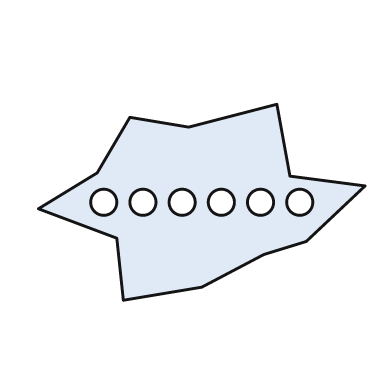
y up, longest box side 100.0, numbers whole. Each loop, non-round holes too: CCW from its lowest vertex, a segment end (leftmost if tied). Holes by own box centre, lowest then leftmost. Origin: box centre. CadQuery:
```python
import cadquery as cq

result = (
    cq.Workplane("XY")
    .moveTo(-24.0, -30.0)
    .lineTo(0.0, -26.0)
    .lineTo(19.0, -16.0)
    .lineTo(32.0, -12.0)
    .lineTo(50.0, 5.0)
    .lineTo(27.0, 8.0)
    .lineTo(23.0, 30.0)
    .lineTo(-4.0, 23.0)
    .lineTo(-22.0, 26.0)
    .lineTo(-32.0, 9.0)
    .lineTo(-50.0, -2.0)
    .lineTo(-26.0, -11.0)
    .close()
    .moveTo(-30.0, 0.0)
    .circle(4.0)
    .moveTo(-18.0, 0.0)
    .circle(4.0)
    .moveTo(-6.0, 0.0)
    .circle(4.0)
    .moveTo(6.0, 0.0)
    .circle(4.0)
    .moveTo(18.0, 0.0)
    .circle(4.0)
    .moveTo(30.0, 0.0)
    .circle(4.0)
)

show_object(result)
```